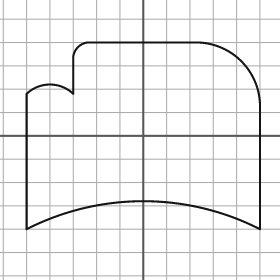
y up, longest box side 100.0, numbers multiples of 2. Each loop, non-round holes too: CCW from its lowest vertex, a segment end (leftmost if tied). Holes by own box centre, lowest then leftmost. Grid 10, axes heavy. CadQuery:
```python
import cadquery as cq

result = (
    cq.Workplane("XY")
    .moveTo(-50.0, -40.0)
    .threePointArc((0.0, -28.0), (50.0, -40.0))
    .lineTo(50.0, 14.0)
    .threePointArc((42.0, 32.0), (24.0, 40.0))
    .lineTo(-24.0, 40.0)
    .threePointArc((-28.0, 38.0), (-30.0, 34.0))
    .lineTo(-30.0, 18.0)
    .threePointArc((-40.0, 22.0), (-50.0, 18.0))
    .close()
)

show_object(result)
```